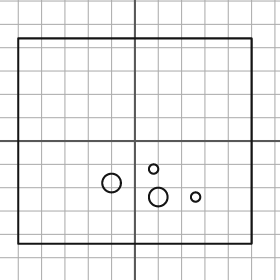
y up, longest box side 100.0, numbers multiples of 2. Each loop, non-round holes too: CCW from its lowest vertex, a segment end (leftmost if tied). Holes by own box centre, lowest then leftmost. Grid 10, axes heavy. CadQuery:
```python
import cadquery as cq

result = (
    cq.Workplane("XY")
    .moveTo(-50.0, -44.0)
    .lineTo(50.0, -44.0)
    .lineTo(50.0, 44.0)
    .lineTo(-50.0, 44.0)
    .close()
    .moveTo(10.0, -24.0)
    .circle(4.0)
    .moveTo(26.0, -24.0)
    .circle(2.0)
    .moveTo(-10.0, -18.0)
    .circle(4.0)
    .moveTo(8.0, -12.0)
    .circle(2.0)
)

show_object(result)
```